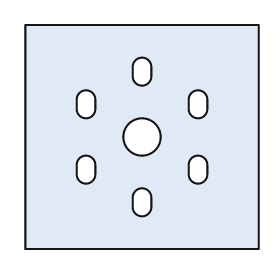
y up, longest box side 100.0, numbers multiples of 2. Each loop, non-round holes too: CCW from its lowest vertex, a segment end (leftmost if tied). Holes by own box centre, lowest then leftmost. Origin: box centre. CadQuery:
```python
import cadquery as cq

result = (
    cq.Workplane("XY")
    .moveTo(-50.0, -48.0)
    .lineTo(50.0, -48.0)
    .lineTo(50.0, 48.0)
    .lineTo(-50.0, 48.0)
    .close()
    .moveTo(-4.0, -30.0)
    .threePointArc((0.0, -34.0), (4.0, -30.0))
    .lineTo(4.0, -26.0)
    .threePointArc((0.0, -22.0), (-4.0, -26.0))
    .close()
    .moveTo(-28.0, -16.0)
    .threePointArc((-24.0, -20.0), (-20.0, -16.0))
    .lineTo(-20.0, -12.0)
    .threePointArc((-24.0, -8.0), (-28.0, -12.0))
    .close()
    .moveTo(20.0, -16.0)
    .threePointArc((24.0, -20.0), (28.0, -16.0))
    .lineTo(28.0, -12.0)
    .threePointArc((24.0, -8.0), (20.0, -12.0))
    .close()
    .moveTo(0.0, 0.0)
    .circle(8.0)
    .moveTo(-28.0, 12.0)
    .threePointArc((-24.0, 8.0), (-20.0, 12.0))
    .lineTo(-20.0, 16.0)
    .threePointArc((-24.0, 20.0), (-28.0, 16.0))
    .close()
    .moveTo(20.0, 12.0)
    .threePointArc((24.0, 8.0), (28.0, 12.0))
    .lineTo(28.0, 16.0)
    .threePointArc((24.0, 20.0), (20.0, 16.0))
    .close()
    .moveTo(-4.0, 26.0)
    .threePointArc((0.0, 22.0), (4.0, 26.0))
    .lineTo(4.0, 30.0)
    .threePointArc((0.0, 34.0), (-4.0, 30.0))
    .close()
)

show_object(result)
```